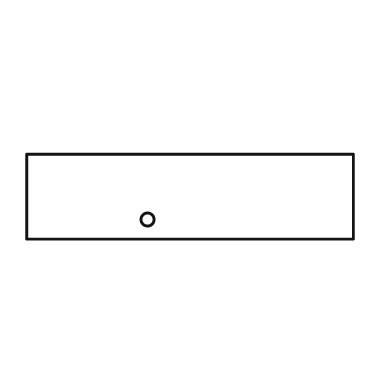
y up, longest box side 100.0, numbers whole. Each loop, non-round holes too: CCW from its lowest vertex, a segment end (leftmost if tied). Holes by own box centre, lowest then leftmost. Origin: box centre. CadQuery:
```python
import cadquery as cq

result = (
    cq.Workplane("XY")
    .moveTo(-50.0, -13.0)
    .lineTo(50.0, -13.0)
    .lineTo(50.0, 13.0)
    .lineTo(-50.0, 13.0)
    .close()
    .moveTo(-13.0, -7.0)
    .circle(2.0)
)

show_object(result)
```